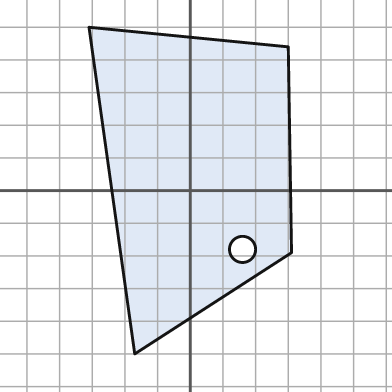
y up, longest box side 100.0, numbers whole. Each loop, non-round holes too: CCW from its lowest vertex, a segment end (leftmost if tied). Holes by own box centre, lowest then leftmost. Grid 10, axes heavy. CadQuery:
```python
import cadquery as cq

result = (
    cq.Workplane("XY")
    .moveTo(-17.0, -50.0)
    .lineTo(31.0, -19.0)
    .lineTo(30.0, 44.0)
    .lineTo(-31.0, 50.0)
    .close()
    .moveTo(16.0, -18.0)
    .circle(4.0)
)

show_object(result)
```